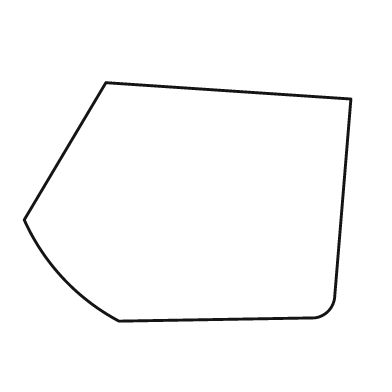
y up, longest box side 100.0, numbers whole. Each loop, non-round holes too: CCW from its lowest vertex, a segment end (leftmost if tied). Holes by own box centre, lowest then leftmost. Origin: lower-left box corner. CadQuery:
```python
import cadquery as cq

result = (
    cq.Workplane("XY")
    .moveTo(29.0, 0.0)
    .lineTo(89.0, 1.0)
    .threePointArc((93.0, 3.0), (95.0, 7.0))
    .lineTo(100.0, 68.0)
    .lineTo(25.0, 73.0)
    .lineTo(0.0, 31.0)
    .threePointArc((12.0, 13.0), (29.0, 0.0))
    .close()
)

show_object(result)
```